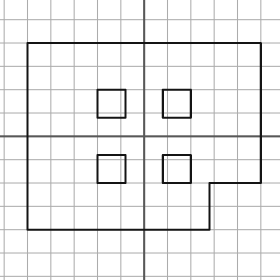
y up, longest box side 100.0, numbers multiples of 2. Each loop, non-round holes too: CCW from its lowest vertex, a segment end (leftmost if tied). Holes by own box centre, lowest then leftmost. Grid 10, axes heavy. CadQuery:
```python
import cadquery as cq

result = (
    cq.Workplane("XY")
    .moveTo(-50.0, -40.0)
    .lineTo(28.0, -40.0)
    .lineTo(28.0, -20.0)
    .lineTo(50.0, -20.0)
    .lineTo(50.0, 40.0)
    .lineTo(-50.0, 40.0)
    .close()
    .moveTo(-20.0, -20.0)
    .lineTo(-8.0, -20.0)
    .lineTo(-8.0, -8.0)
    .lineTo(-20.0, -8.0)
    .close()
    .moveTo(8.0, -20.0)
    .lineTo(20.0, -20.0)
    .lineTo(20.0, -8.0)
    .lineTo(8.0, -8.0)
    .close()
    .moveTo(-20.0, 8.0)
    .lineTo(-8.0, 8.0)
    .lineTo(-8.0, 20.0)
    .lineTo(-20.0, 20.0)
    .close()
    .moveTo(8.0, 8.0)
    .lineTo(20.0, 8.0)
    .lineTo(20.0, 20.0)
    .lineTo(8.0, 20.0)
    .close()
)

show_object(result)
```